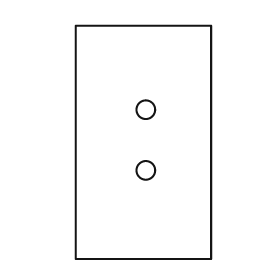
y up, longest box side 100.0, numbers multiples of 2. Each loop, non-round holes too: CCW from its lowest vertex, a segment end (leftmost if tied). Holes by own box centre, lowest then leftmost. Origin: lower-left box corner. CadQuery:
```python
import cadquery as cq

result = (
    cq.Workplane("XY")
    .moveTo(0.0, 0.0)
    .lineTo(58.0, 0.0)
    .lineTo(58.0, 100.0)
    .lineTo(0.0, 100.0)
    .close()
    .moveTo(30.0, 38.0)
    .circle(4.0)
    .moveTo(30.0, 64.0)
    .circle(4.0)
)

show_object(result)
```